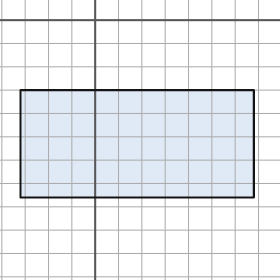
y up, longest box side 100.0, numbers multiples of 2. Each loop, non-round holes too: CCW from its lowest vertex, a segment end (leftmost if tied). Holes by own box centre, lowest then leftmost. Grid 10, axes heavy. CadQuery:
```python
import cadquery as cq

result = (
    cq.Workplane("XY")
    .moveTo(-32.0, -76.0)
    .lineTo(68.0, -76.0)
    .lineTo(68.0, -30.0)
    .lineTo(-32.0, -30.0)
    .close()
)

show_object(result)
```